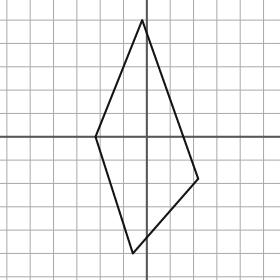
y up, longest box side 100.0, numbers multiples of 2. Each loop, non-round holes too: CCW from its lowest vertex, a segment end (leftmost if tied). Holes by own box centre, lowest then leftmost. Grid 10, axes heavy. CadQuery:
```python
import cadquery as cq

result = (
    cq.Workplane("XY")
    .moveTo(-6.0, -50.0)
    .lineTo(22.0, -18.0)
    .lineTo(-2.0, 50.0)
    .lineTo(-22.0, 0.0)
    .close()
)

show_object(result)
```